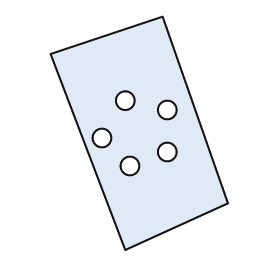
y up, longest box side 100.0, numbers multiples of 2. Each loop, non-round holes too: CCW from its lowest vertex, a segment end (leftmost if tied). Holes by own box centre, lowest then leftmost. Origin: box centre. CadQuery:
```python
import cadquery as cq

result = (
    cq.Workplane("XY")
    .moveTo(-6.0, -50.0)
    .lineTo(38.0, -30.0)
    .lineTo(10.0, 50.0)
    .lineTo(-38.0, 34.0)
    .close()
    .moveTo(-4.0, -14.0)
    .circle(4.0)
    .moveTo(12.0, -8.0)
    .circle(4.0)
    .moveTo(-16.0, -2.0)
    .circle(4.0)
    .moveTo(12.0, 10.0)
    .circle(4.0)
    .moveTo(-6.0, 14.0)
    .circle(4.0)
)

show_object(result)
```